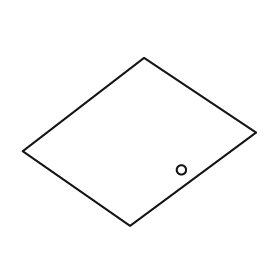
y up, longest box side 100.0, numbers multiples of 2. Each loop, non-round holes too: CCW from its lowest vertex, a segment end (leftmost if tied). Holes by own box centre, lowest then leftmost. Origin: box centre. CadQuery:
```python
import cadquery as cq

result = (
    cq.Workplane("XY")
    .moveTo(-4.0, -36.0)
    .lineTo(50.0, 4.0)
    .lineTo(2.0, 36.0)
    .lineTo(-50.0, -4.0)
    .close()
    .moveTo(18.0, -12.0)
    .circle(2.0)
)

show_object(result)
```